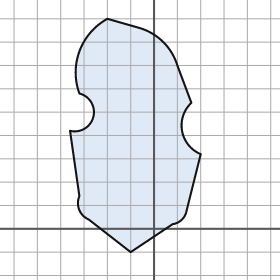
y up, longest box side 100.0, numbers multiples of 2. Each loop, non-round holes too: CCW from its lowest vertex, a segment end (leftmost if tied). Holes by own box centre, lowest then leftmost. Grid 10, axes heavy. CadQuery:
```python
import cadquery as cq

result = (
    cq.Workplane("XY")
    .moveTo(-10.0, -10.0)
    .lineTo(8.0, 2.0)
    .threePointArc((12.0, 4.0), (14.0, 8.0))
    .lineTo(20.0, 32.0)
    .threePointArc((12.0, 42.0), (16.0, 54.0))
    .lineTo(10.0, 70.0)
    .threePointArc((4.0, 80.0), (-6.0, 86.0))
    .lineTo(-20.0, 90.0)
    .threePointArc((-32.0, 76.0), (-32.0, 58.0))
    .threePointArc((-26.0, 48.0), (-36.0, 42.0))
    .lineTo(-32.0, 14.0)
    .threePointArc((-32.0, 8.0), (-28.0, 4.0))
    .close()
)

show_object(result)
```